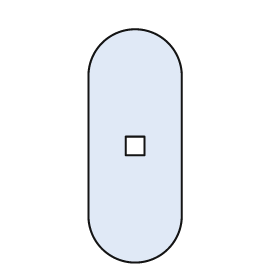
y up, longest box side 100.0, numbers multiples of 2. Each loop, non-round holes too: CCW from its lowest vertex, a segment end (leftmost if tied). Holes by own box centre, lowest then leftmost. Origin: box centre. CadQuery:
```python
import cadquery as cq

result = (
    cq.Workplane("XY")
    .moveTo(-20.0, -30.0)
    .threePointArc((0.0, -50.0), (20.0, -30.0))
    .lineTo(20.0, 30.0)
    .threePointArc((0.0, 50.0), (-20.0, 30.0))
    .close()
    .moveTo(-4.0, -4.0)
    .lineTo(4.0, -4.0)
    .lineTo(4.0, 4.0)
    .lineTo(-4.0, 4.0)
    .close()
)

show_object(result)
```